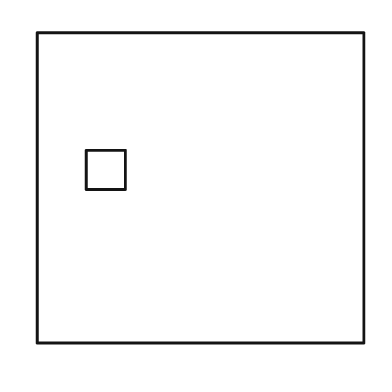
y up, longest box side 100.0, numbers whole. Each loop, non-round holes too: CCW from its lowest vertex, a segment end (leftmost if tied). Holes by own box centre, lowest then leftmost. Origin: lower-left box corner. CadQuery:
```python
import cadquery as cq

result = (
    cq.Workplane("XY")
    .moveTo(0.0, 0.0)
    .lineTo(100.0, 0.0)
    .lineTo(100.0, 95.0)
    .lineTo(0.0, 95.0)
    .close()
    .moveTo(15.0, 47.0)
    .lineTo(27.0, 47.0)
    .lineTo(27.0, 59.0)
    .lineTo(15.0, 59.0)
    .close()
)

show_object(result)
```